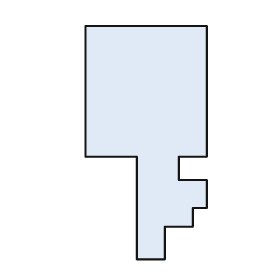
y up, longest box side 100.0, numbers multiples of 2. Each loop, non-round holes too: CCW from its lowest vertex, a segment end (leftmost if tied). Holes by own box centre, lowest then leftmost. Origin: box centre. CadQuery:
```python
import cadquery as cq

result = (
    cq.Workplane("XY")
    .moveTo(-4.0, -50.0)
    .lineTo(8.0, -50.0)
    .lineTo(8.0, -36.0)
    .lineTo(20.0, -36.0)
    .lineTo(20.0, -28.0)
    .lineTo(26.0, -28.0)
    .lineTo(26.0, -16.0)
    .lineTo(14.0, -16.0)
    .lineTo(14.0, -6.0)
    .lineTo(26.0, -6.0)
    .lineTo(26.0, 50.0)
    .lineTo(-26.0, 50.0)
    .lineTo(-26.0, -6.0)
    .lineTo(-4.0, -6.0)
    .close()
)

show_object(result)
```